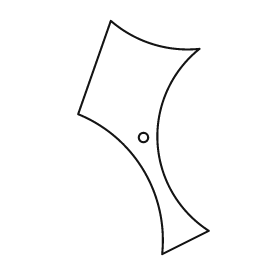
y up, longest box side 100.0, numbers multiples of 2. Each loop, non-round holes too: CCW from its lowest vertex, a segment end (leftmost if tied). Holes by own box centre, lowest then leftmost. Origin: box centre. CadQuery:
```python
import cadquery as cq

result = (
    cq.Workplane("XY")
    .moveTo(8.0, -50.0)
    .lineTo(28.0, -40.0)
    .threePointArc((6.0, -2.0), (24.0, 38.0))
    .threePointArc((4.0, 40.0), (-14.0, 50.0))
    .lineTo(-28.0, 10.0)
    .threePointArc((0.0, -14.0), (8.0, -50.0))
    .close()
    .moveTo(0.0, 0.0)
    .circle(2.0)
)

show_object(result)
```